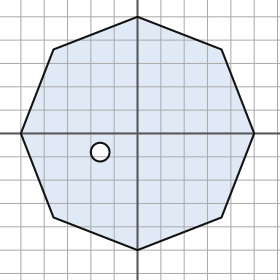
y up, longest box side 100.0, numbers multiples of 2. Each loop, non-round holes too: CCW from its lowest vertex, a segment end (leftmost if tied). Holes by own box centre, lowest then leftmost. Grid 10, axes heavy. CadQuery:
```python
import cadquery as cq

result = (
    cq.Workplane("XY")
    .moveTo(0.0, -50.0)
    .lineTo(36.0, -36.0)
    .lineTo(50.0, 0.0)
    .lineTo(36.0, 36.0)
    .lineTo(0.0, 50.0)
    .lineTo(-36.0, 36.0)
    .lineTo(-50.0, 0.0)
    .lineTo(-36.0, -36.0)
    .close()
    .moveTo(-16.0, -8.0)
    .circle(4.0)
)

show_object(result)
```